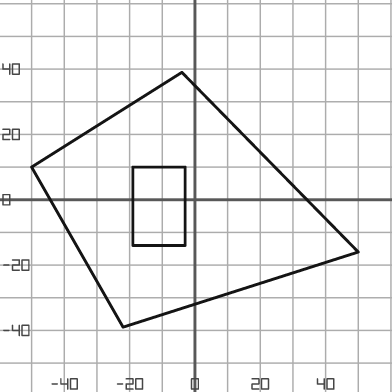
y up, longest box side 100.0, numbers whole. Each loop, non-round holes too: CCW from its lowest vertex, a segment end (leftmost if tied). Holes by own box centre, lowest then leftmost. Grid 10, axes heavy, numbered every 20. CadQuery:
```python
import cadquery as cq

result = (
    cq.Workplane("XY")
    .moveTo(-22.0, -39.0)
    .lineTo(50.0, -16.0)
    .lineTo(-4.0, 39.0)
    .lineTo(-50.0, 10.0)
    .close()
    .moveTo(-19.0, -14.0)
    .lineTo(-3.0, -14.0)
    .lineTo(-3.0, 10.0)
    .lineTo(-19.0, 10.0)
    .close()
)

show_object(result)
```